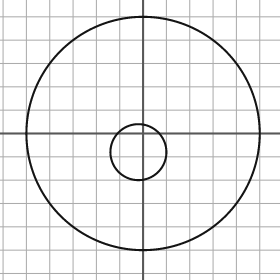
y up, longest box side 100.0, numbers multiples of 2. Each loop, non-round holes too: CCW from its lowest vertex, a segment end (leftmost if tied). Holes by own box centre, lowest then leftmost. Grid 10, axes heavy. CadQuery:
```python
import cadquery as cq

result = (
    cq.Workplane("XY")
    .moveTo(0.0, 0.0)
    .circle(50.0)
    .moveTo(-2.0, -8.0)
    .circle(12.0)
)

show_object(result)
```